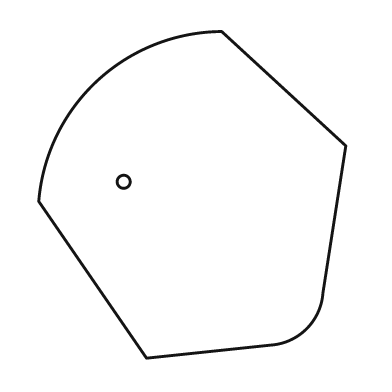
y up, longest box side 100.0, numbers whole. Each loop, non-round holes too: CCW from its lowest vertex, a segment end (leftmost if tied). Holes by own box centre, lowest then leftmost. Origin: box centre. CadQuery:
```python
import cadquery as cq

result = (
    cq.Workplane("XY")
    .moveTo(-14.0, -50.0)
    .lineTo(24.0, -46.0)
    .threePointArc((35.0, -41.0), (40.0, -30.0))
    .lineTo(47.0, 15.0)
    .lineTo(9.0, 50.0)
    .threePointArc((-29.0, 35.0), (-47.0, -2.0))
    .close()
    .moveTo(-21.0, 4.0)
    .circle(2.0)
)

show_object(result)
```